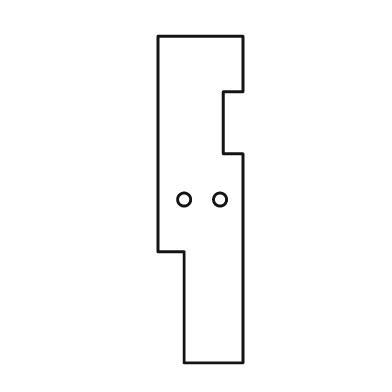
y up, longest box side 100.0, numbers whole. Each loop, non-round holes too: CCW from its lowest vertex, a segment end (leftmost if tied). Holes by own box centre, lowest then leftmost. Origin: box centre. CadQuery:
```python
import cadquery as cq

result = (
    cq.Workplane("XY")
    .moveTo(-5.0, -50.0)
    .lineTo(13.0, -50.0)
    .lineTo(13.0, 14.0)
    .lineTo(7.0, 14.0)
    .lineTo(7.0, 33.0)
    .lineTo(13.0, 33.0)
    .lineTo(13.0, 50.0)
    .lineTo(-13.0, 50.0)
    .lineTo(-13.0, -16.0)
    .lineTo(-5.0, -16.0)
    .close()
    .moveTo(-5.0, 0.0)
    .circle(2.0)
    .moveTo(6.0, 0.0)
    .circle(2.0)
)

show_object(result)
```